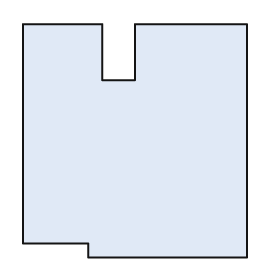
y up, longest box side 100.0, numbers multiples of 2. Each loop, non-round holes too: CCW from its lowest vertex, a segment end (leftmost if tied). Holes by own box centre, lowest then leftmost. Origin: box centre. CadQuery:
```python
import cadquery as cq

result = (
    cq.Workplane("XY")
    .moveTo(-20.0, -50.0)
    .lineTo(48.0, -50.0)
    .lineTo(48.0, 50.0)
    .lineTo(0.0, 50.0)
    .lineTo(0.0, 26.0)
    .lineTo(-14.0, 26.0)
    .lineTo(-14.0, 50.0)
    .lineTo(-48.0, 50.0)
    .lineTo(-48.0, -44.0)
    .lineTo(-20.0, -44.0)
    .close()
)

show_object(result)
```